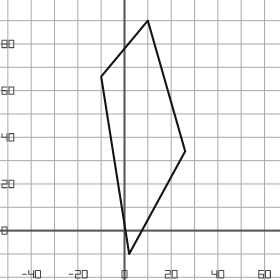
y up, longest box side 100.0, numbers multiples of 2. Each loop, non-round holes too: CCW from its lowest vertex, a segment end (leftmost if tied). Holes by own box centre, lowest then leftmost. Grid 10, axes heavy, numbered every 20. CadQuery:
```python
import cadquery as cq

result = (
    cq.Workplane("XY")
    .moveTo(2.0, -10.0)
    .lineTo(26.0, 34.0)
    .lineTo(10.0, 90.0)
    .lineTo(-10.0, 66.0)
    .close()
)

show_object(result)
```